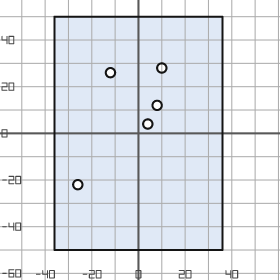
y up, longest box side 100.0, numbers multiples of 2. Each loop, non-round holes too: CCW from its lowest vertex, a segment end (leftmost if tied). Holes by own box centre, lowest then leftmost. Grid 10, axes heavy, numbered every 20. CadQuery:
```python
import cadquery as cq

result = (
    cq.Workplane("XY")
    .moveTo(-36.0, -50.0)
    .lineTo(36.0, -50.0)
    .lineTo(36.0, 50.0)
    .lineTo(-36.0, 50.0)
    .close()
    .moveTo(-26.0, -22.0)
    .circle(2.0)
    .moveTo(4.0, 4.0)
    .circle(2.0)
    .moveTo(8.0, 12.0)
    .circle(2.0)
    .moveTo(-12.0, 26.0)
    .circle(2.0)
    .moveTo(10.0, 28.0)
    .circle(2.0)
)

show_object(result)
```